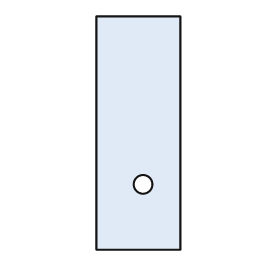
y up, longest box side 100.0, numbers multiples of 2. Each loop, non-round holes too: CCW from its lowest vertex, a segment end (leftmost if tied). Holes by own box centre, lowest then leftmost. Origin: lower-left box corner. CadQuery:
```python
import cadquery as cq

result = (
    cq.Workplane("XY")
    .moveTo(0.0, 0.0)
    .lineTo(36.0, 0.0)
    .lineTo(36.0, 100.0)
    .lineTo(0.0, 100.0)
    .close()
    .moveTo(20.0, 28.0)
    .circle(4.0)
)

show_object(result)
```